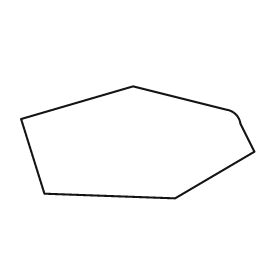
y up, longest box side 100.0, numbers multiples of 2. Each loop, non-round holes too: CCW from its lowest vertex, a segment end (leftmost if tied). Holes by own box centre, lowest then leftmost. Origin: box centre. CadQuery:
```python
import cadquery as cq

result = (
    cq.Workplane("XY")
    .moveTo(16.0, -24.0)
    .lineTo(50.0, -4.0)
    .lineTo(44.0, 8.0)
    .threePointArc((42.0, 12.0), (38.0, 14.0))
    .lineTo(-2.0, 24.0)
    .lineTo(-50.0, 10.0)
    .lineTo(-40.0, -22.0)
    .close()
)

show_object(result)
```